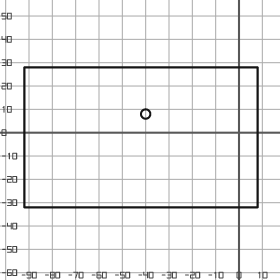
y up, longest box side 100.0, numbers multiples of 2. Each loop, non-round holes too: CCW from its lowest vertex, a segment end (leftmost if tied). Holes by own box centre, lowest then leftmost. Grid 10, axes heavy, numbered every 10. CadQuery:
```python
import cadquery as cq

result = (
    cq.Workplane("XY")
    .moveTo(-92.0, -32.0)
    .lineTo(8.0, -32.0)
    .lineTo(8.0, 28.0)
    .lineTo(-92.0, 28.0)
    .close()
    .moveTo(-40.0, 8.0)
    .circle(2.0)
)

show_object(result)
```